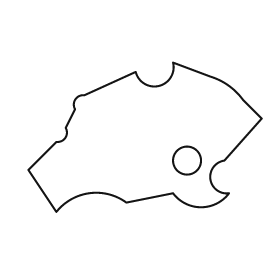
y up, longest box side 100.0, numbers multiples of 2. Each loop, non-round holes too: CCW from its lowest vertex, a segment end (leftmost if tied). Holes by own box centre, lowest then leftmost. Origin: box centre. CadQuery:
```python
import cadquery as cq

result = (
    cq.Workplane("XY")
    .moveTo(-38.0, -32.0)
    .threePointArc((-24.0, -24.0), (-8.0, -28.0))
    .lineTo(12.0, -24.0)
    .threePointArc((24.0, -30.0), (36.0, -24.0))
    .threePointArc((28.0, -18.0), (34.0, -10.0))
    .lineTo(50.0, 8.0)
    .lineTo(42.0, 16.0)
    .threePointArc((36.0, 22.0), (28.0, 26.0))
    .lineTo(12.0, 32.0)
    .threePointArc((6.0, 22.0), (-4.0, 28.0))
    .lineTo(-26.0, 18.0)
    .threePointArc((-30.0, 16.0), (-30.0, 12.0))
    .lineTo(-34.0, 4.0)
    .threePointArc((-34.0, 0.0), (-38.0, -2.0))
    .lineTo(-50.0, -14.0)
    .close()
    .moveTo(18.0, -10.0)
    .circle(6.0)
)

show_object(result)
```